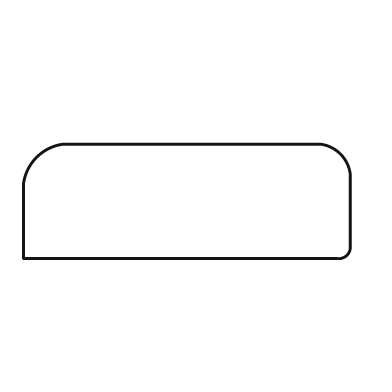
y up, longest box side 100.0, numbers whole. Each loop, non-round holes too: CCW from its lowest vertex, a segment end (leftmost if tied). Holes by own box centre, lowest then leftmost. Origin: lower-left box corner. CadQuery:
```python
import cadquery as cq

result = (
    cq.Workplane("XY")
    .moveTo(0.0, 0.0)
    .lineTo(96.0, 0.0)
    .threePointArc((99.0, 1.0), (100.0, 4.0))
    .lineTo(100.0, 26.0)
    .threePointArc((97.0, 32.0), (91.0, 35.0))
    .lineTo(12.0, 35.0)
    .threePointArc((4.0, 31.0), (0.0, 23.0))
    .close()
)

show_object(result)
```